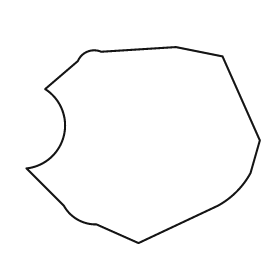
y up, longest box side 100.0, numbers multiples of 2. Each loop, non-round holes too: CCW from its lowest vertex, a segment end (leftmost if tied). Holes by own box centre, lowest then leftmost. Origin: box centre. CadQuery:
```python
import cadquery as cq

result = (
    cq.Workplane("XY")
    .moveTo(-2.0, -42.0)
    .lineTo(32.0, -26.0)
    .threePointArc((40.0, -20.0), (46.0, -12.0))
    .lineTo(50.0, 2.0)
    .lineTo(34.0, 38.0)
    .lineTo(14.0, 42.0)
    .lineTo(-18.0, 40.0)
    .threePointArc((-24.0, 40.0), (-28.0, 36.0))
    .lineTo(-42.0, 24.0)
    .threePointArc((-34.0, 4.0), (-50.0, -10.0))
    .lineTo(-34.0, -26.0)
    .threePointArc((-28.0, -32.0), (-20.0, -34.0))
    .close()
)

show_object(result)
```